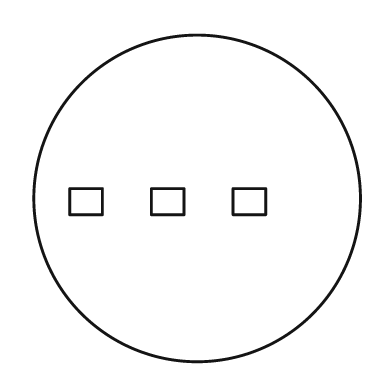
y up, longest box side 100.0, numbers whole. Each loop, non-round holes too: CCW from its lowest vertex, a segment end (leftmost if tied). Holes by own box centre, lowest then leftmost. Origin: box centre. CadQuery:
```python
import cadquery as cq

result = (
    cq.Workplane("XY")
    .moveTo(0.0, 0.0)
    .circle(50.0)
    .moveTo(-39.0, -5.0)
    .lineTo(-29.0, -5.0)
    .lineTo(-29.0, 3.0)
    .lineTo(-39.0, 3.0)
    .close()
    .moveTo(-14.0, -5.0)
    .lineTo(-4.0, -5.0)
    .lineTo(-4.0, 3.0)
    .lineTo(-14.0, 3.0)
    .close()
    .moveTo(11.0, -5.0)
    .lineTo(21.0, -5.0)
    .lineTo(21.0, 3.0)
    .lineTo(11.0, 3.0)
    .close()
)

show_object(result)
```